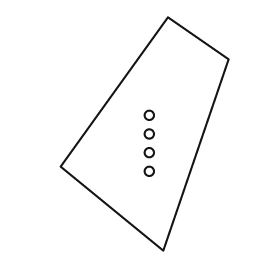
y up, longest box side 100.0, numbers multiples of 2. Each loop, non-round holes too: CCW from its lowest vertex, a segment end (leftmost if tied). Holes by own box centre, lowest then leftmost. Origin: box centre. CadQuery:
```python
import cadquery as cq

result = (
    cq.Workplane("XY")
    .moveTo(8.0, -50.0)
    .lineTo(36.0, 32.0)
    .lineTo(10.0, 50.0)
    .lineTo(-36.0, -14.0)
    .close()
    .moveTo(2.0, -16.0)
    .circle(2.0)
    .moveTo(2.0, -8.0)
    .circle(2.0)
    .moveTo(2.0, 0.0)
    .circle(2.0)
    .moveTo(2.0, 8.0)
    .circle(2.0)
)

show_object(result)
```